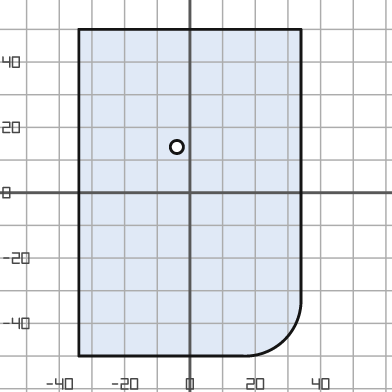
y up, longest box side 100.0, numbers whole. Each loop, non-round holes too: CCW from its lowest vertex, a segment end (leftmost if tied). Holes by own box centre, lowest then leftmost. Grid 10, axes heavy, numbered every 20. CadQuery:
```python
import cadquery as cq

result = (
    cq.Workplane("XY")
    .moveTo(-34.0, -50.0)
    .lineTo(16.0, -50.0)
    .threePointArc((29.0, -45.0), (34.0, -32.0))
    .lineTo(34.0, 50.0)
    .lineTo(-34.0, 50.0)
    .close()
    .moveTo(-4.0, 14.0)
    .circle(2.0)
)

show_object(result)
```